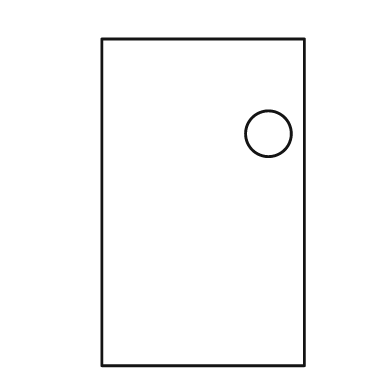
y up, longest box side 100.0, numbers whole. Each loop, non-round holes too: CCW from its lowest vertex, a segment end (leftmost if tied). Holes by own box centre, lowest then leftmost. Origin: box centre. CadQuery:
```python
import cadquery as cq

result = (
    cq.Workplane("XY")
    .moveTo(-31.0, -50.0)
    .lineTo(31.0, -50.0)
    .lineTo(31.0, 50.0)
    .lineTo(-31.0, 50.0)
    .close()
    .moveTo(20.0, 21.0)
    .circle(7.0)
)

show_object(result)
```